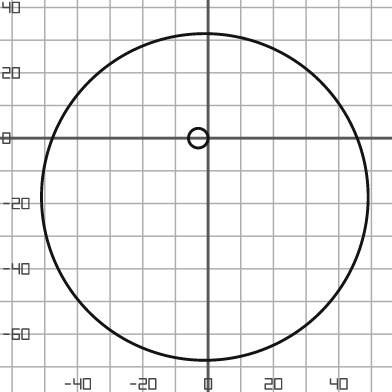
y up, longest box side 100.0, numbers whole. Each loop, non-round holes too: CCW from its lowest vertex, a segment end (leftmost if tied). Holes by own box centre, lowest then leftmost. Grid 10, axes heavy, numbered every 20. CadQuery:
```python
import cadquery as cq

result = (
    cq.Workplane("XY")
    .moveTo(-1.0, -18.0)
    .circle(50.0)
    .moveTo(-3.0, 0.0)
    .circle(3.0)
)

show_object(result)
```